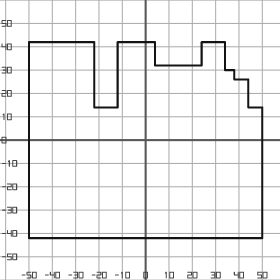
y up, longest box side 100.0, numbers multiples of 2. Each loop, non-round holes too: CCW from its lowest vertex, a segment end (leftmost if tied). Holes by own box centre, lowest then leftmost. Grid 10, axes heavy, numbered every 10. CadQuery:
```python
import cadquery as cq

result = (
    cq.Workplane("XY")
    .moveTo(-50.0, -42.0)
    .lineTo(50.0, -42.0)
    .lineTo(50.0, 14.0)
    .lineTo(44.0, 14.0)
    .lineTo(44.0, 26.0)
    .lineTo(38.0, 26.0)
    .lineTo(38.0, 30.0)
    .lineTo(34.0, 30.0)
    .lineTo(34.0, 42.0)
    .lineTo(24.0, 42.0)
    .lineTo(24.0, 32.0)
    .lineTo(4.0, 32.0)
    .lineTo(4.0, 42.0)
    .lineTo(-12.0, 42.0)
    .lineTo(-12.0, 14.0)
    .lineTo(-22.0, 14.0)
    .lineTo(-22.0, 42.0)
    .lineTo(-50.0, 42.0)
    .close()
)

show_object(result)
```